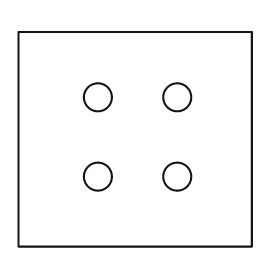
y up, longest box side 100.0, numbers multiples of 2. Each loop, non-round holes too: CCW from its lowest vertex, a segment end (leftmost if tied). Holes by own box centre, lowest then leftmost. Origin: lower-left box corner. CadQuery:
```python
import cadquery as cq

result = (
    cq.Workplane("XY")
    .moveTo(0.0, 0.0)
    .lineTo(100.0, 0.0)
    .lineTo(100.0, 92.0)
    .lineTo(0.0, 92.0)
    .close()
    .moveTo(34.0, 30.0)
    .circle(6.0)
    .moveTo(68.0, 30.0)
    .circle(6.0)
    .moveTo(34.0, 64.0)
    .circle(6.0)
    .moveTo(68.0, 64.0)
    .circle(6.0)
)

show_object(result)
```